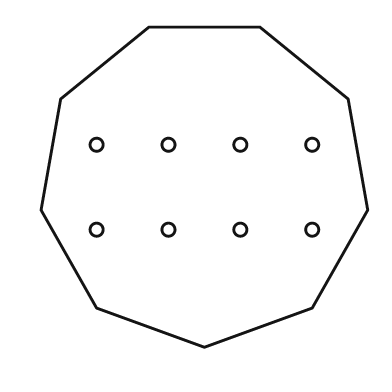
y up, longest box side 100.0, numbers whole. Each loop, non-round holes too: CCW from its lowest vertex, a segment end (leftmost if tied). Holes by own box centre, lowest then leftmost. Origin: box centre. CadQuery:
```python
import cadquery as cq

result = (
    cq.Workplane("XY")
    .moveTo(0.0, -49.0)
    .lineTo(33.0, -37.0)
    .lineTo(50.0, -7.0)
    .lineTo(44.0, 27.0)
    .lineTo(17.0, 49.0)
    .lineTo(-17.0, 49.0)
    .lineTo(-44.0, 27.0)
    .lineTo(-50.0, -7.0)
    .lineTo(-33.0, -37.0)
    .close()
    .moveTo(-33.0, -13.0)
    .circle(2.0)
    .moveTo(-11.0, -13.0)
    .circle(2.0)
    .moveTo(11.0, -13.0)
    .circle(2.0)
    .moveTo(33.0, -13.0)
    .circle(2.0)
    .moveTo(-33.0, 13.0)
    .circle(2.0)
    .moveTo(-11.0, 13.0)
    .circle(2.0)
    .moveTo(11.0, 13.0)
    .circle(2.0)
    .moveTo(33.0, 13.0)
    .circle(2.0)
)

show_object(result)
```